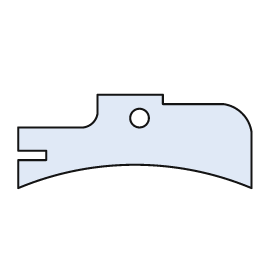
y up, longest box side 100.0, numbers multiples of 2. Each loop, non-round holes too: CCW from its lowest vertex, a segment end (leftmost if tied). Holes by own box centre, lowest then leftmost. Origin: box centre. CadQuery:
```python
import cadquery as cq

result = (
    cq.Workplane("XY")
    .moveTo(-50.0, -20.0)
    .threePointArc((0.0, -10.0), (50.0, -20.0))
    .lineTo(50.0, 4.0)
    .threePointArc((46.0, 12.0), (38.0, 16.0))
    .lineTo(12.0, 16.0)
    .lineTo(12.0, 20.0)
    .lineTo(-16.0, 20.0)
    .lineTo(-16.0, 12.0)
    .threePointArc((-18.0, 8.0), (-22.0, 6.0))
    .lineTo(-50.0, 6.0)
    .lineTo(-50.0, -4.0)
    .lineTo(-38.0, -4.0)
    .lineTo(-38.0, -8.0)
    .lineTo(-50.0, -8.0)
    .close()
    .moveTo(2.0, 10.0)
    .circle(4.0)
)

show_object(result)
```